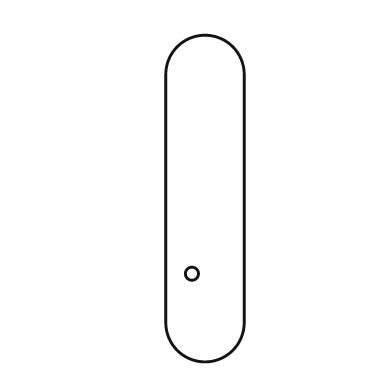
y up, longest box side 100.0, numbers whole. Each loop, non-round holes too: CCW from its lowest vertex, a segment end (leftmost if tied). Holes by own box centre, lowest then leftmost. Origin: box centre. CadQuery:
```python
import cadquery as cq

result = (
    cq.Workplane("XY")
    .moveTo(-12.0, -38.0)
    .threePointArc((0.0, -50.0), (12.0, -38.0))
    .lineTo(12.0, 38.0)
    .threePointArc((0.0, 50.0), (-12.0, 38.0))
    .close()
    .moveTo(-4.0, -23.0)
    .circle(2.0)
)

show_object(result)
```